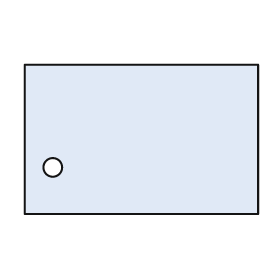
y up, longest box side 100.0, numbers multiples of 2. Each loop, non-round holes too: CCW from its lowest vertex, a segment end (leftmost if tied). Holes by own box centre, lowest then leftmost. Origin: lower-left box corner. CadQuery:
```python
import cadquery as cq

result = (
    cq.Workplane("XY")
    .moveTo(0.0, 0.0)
    .lineTo(100.0, 0.0)
    .lineTo(100.0, 64.0)
    .lineTo(0.0, 64.0)
    .close()
    .moveTo(12.0, 20.0)
    .circle(4.0)
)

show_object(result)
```